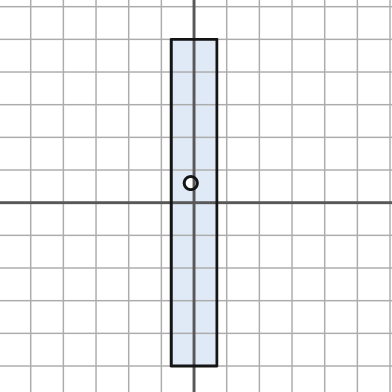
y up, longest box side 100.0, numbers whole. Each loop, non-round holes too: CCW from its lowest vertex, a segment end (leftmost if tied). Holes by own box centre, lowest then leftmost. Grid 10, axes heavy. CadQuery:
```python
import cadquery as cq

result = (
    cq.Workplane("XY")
    .moveTo(-7.0, -50.0)
    .lineTo(7.0, -50.0)
    .lineTo(7.0, 50.0)
    .lineTo(-7.0, 50.0)
    .close()
    .moveTo(-1.0, 6.0)
    .circle(2.0)
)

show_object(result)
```